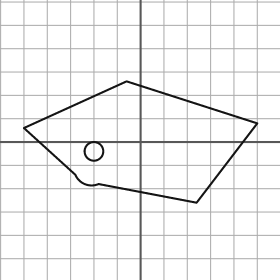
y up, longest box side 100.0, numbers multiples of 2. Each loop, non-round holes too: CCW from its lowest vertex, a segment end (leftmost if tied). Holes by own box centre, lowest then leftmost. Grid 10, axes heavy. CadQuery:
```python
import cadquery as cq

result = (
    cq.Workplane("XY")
    .moveTo(24.0, -26.0)
    .lineTo(50.0, 8.0)
    .lineTo(-6.0, 26.0)
    .lineTo(-50.0, 6.0)
    .lineTo(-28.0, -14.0)
    .threePointArc((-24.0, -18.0), (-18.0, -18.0))
    .close()
    .moveTo(-20.0, -4.0)
    .circle(4.0)
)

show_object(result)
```